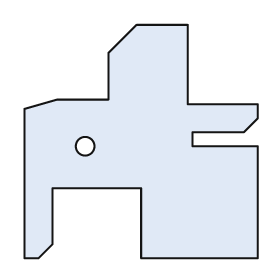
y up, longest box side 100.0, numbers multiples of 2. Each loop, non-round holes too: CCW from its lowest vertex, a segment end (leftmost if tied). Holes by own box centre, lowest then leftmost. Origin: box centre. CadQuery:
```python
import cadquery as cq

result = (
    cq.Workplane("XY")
    .moveTo(-50.0, -50.0)
    .lineTo(-44.0, -50.0)
    .lineTo(-38.0, -44.0)
    .lineTo(-38.0, -20.0)
    .lineTo(0.0, -20.0)
    .lineTo(0.0, -50.0)
    .lineTo(50.0, -50.0)
    .lineTo(50.0, -2.0)
    .lineTo(22.0, -2.0)
    .lineTo(22.0, 4.0)
    .lineTo(44.0, 4.0)
    .lineTo(50.0, 10.0)
    .lineTo(50.0, 16.0)
    .lineTo(20.0, 16.0)
    .lineTo(20.0, 50.0)
    .lineTo(-2.0, 50.0)
    .lineTo(-14.0, 38.0)
    .lineTo(-14.0, 18.0)
    .lineTo(-36.0, 18.0)
    .lineTo(-50.0, 14.0)
    .close()
    .moveTo(-24.0, -2.0)
    .circle(4.0)
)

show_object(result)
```